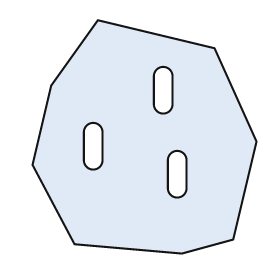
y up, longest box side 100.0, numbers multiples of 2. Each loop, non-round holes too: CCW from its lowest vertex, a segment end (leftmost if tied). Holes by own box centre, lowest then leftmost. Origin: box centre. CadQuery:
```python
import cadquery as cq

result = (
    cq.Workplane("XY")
    .moveTo(16.0, -50.0)
    .lineTo(38.0, -44.0)
    .lineTo(48.0, -2.0)
    .lineTo(30.0, 38.0)
    .lineTo(-20.0, 50.0)
    .lineTo(-40.0, 22.0)
    .lineTo(-48.0, -12.0)
    .lineTo(-30.0, -46.0)
    .close()
    .moveTo(10.0, -22.0)
    .threePointArc((14.0, -26.0), (18.0, -22.0))
    .lineTo(18.0, -10.0)
    .threePointArc((14.0, -6.0), (10.0, -10.0))
    .close()
    .moveTo(-26.0, -10.0)
    .threePointArc((-22.0, -14.0), (-18.0, -10.0))
    .lineTo(-18.0, 2.0)
    .threePointArc((-22.0, 6.0), (-26.0, 2.0))
    .close()
    .moveTo(4.0, 14.0)
    .threePointArc((8.0, 10.0), (12.0, 14.0))
    .lineTo(12.0, 26.0)
    .threePointArc((8.0, 30.0), (4.0, 26.0))
    .close()
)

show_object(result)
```